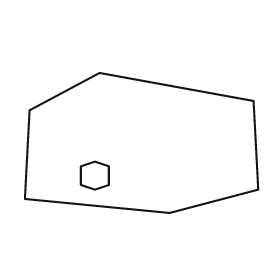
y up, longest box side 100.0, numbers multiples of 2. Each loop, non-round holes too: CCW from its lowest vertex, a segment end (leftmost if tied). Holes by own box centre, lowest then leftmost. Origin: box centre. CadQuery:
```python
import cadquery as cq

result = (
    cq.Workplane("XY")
    .moveTo(12.0, -30.0)
    .lineTo(50.0, -20.0)
    .lineTo(48.0, 18.0)
    .lineTo(-18.0, 30.0)
    .lineTo(-48.0, 14.0)
    .lineTo(-50.0, -24.0)
    .close()
    .moveTo(-20.0, -20.0)
    .lineTo(-14.0, -18.0)
    .lineTo(-14.0, -10.0)
    .lineTo(-20.0, -8.0)
    .lineTo(-26.0, -10.0)
    .lineTo(-26.0, -18.0)
    .close()
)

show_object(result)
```